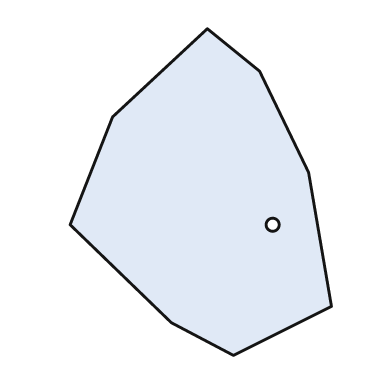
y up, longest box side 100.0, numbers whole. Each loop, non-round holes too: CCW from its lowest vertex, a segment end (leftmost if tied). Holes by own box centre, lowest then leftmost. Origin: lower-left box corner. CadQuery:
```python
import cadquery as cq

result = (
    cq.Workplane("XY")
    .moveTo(50.0, 0.0)
    .lineTo(80.0, 15.0)
    .lineTo(73.0, 56.0)
    .lineTo(58.0, 87.0)
    .lineTo(42.0, 100.0)
    .lineTo(13.0, 73.0)
    .lineTo(0.0, 40.0)
    .lineTo(31.0, 10.0)
    .close()
    .moveTo(62.0, 40.0)
    .circle(2.0)
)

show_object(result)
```